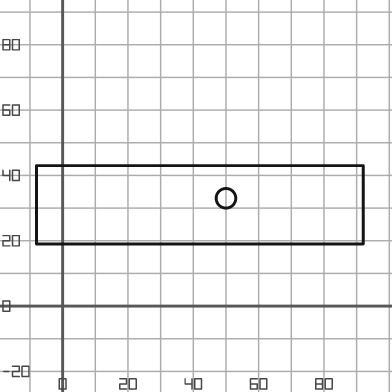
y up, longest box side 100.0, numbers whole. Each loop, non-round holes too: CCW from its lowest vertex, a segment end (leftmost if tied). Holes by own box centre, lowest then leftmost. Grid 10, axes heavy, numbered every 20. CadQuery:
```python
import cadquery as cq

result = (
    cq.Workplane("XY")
    .moveTo(-8.0, 19.0)
    .lineTo(92.0, 19.0)
    .lineTo(92.0, 43.0)
    .lineTo(-8.0, 43.0)
    .close()
    .moveTo(50.0, 33.0)
    .circle(3.0)
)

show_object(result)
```